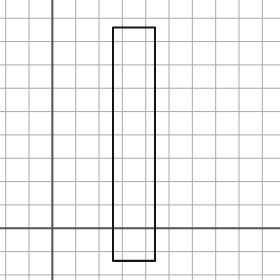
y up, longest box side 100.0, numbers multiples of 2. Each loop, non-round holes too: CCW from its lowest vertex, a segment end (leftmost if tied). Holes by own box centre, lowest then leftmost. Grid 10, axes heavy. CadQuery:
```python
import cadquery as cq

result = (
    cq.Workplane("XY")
    .moveTo(26.0, -14.0)
    .lineTo(44.0, -14.0)
    .lineTo(44.0, 86.0)
    .lineTo(26.0, 86.0)
    .close()
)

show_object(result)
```